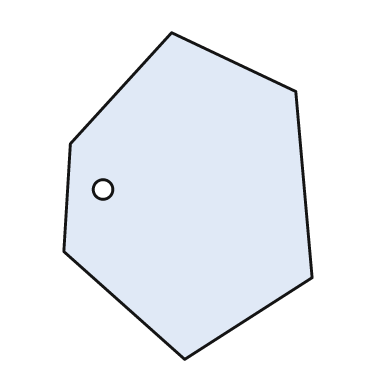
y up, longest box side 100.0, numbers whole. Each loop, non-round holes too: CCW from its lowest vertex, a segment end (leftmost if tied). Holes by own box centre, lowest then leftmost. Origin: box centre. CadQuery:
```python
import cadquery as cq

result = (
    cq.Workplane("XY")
    .moveTo(-1.0, -50.0)
    .lineTo(38.0, -25.0)
    .lineTo(33.0, 32.0)
    .lineTo(-5.0, 50.0)
    .lineTo(-36.0, 16.0)
    .lineTo(-38.0, -17.0)
    .close()
    .moveTo(-26.0, 2.0)
    .circle(3.0)
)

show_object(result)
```